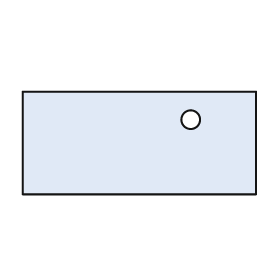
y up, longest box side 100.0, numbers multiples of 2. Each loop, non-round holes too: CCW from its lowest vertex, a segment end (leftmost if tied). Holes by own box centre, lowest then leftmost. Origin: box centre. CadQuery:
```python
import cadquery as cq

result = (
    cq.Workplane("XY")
    .moveTo(-50.0, -22.0)
    .lineTo(50.0, -22.0)
    .lineTo(50.0, 22.0)
    .lineTo(-50.0, 22.0)
    .close()
    .moveTo(22.0, 10.0)
    .circle(4.0)
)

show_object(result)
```